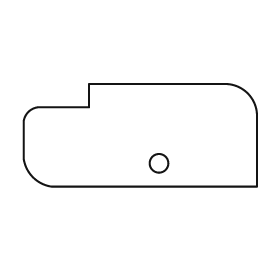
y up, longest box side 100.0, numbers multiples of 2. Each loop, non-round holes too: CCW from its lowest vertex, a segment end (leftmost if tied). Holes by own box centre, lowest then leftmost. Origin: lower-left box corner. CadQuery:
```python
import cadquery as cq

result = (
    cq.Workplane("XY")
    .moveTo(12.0, 0.0)
    .lineTo(100.0, 0.0)
    .lineTo(100.0, 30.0)
    .threePointArc((96.0, 40.0), (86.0, 44.0))
    .lineTo(28.0, 44.0)
    .lineTo(28.0, 34.0)
    .lineTo(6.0, 34.0)
    .threePointArc((2.0, 32.0), (0.0, 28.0))
    .lineTo(0.0, 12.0)
    .threePointArc((4.0, 4.0), (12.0, 0.0))
    .close()
    .moveTo(58.0, 10.0)
    .circle(4.0)
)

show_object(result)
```